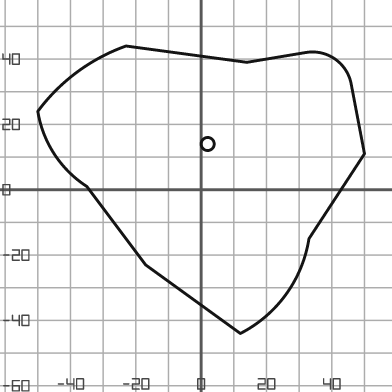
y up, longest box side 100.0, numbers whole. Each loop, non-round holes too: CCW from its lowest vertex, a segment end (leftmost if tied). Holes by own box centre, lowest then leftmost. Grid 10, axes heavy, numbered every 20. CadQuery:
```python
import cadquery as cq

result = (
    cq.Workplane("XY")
    .moveTo(12.0, -44.0)
    .threePointArc((26.0, -32.0), (33.0, -15.0))
    .lineTo(50.0, 11.0)
    .lineTo(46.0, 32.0)
    .threePointArc((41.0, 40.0), (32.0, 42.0))
    .lineTo(14.0, 39.0)
    .lineTo(-23.0, 44.0)
    .threePointArc((-38.0, 36.0), (-50.0, 24.0))
    .threePointArc((-45.0, 11.0), (-35.0, 1.0))
    .lineTo(-17.0, -23.0)
    .close()
    .moveTo(2.0, 14.0)
    .circle(2.0)
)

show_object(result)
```